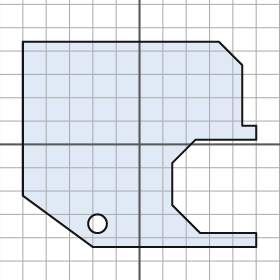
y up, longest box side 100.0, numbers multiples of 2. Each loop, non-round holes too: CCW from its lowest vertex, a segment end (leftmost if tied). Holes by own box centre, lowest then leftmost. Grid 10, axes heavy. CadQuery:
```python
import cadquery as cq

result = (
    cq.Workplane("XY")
    .moveTo(-20.0, -44.0)
    .lineTo(50.0, -44.0)
    .lineTo(50.0, -38.0)
    .lineTo(26.0, -38.0)
    .lineTo(14.0, -26.0)
    .lineTo(14.0, -8.0)
    .lineTo(24.0, 2.0)
    .lineTo(50.0, 2.0)
    .lineTo(50.0, 8.0)
    .lineTo(44.0, 8.0)
    .lineTo(44.0, 34.0)
    .lineTo(34.0, 44.0)
    .lineTo(-50.0, 44.0)
    .lineTo(-50.0, -22.0)
    .close()
    .moveTo(-18.0, -34.0)
    .circle(4.0)
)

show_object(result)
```